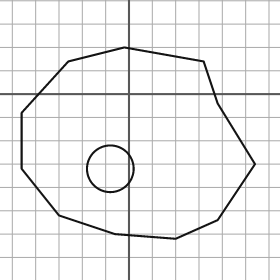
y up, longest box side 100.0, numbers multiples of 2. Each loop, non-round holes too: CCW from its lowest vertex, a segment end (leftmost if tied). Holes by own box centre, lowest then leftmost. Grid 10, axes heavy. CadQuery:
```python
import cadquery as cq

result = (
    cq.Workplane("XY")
    .moveTo(20.0, -62.0)
    .lineTo(38.0, -54.0)
    .lineTo(54.0, -30.0)
    .lineTo(38.0, -4.0)
    .lineTo(32.0, 14.0)
    .lineTo(-2.0, 20.0)
    .lineTo(-26.0, 14.0)
    .lineTo(-46.0, -8.0)
    .lineTo(-46.0, -32.0)
    .lineTo(-30.0, -52.0)
    .lineTo(-6.0, -60.0)
    .close()
    .moveTo(-8.0, -32.0)
    .circle(10.0)
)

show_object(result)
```